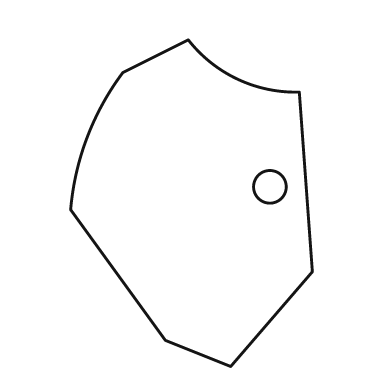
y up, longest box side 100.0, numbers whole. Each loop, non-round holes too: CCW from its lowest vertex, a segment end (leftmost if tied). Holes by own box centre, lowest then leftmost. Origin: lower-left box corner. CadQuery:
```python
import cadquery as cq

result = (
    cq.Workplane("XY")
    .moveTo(49.0, 0.0)
    .lineTo(74.0, 29.0)
    .lineTo(70.0, 84.0)
    .threePointArc((51.0, 88.0), (36.0, 100.0))
    .lineTo(16.0, 90.0)
    .threePointArc((5.0, 70.0), (0.0, 48.0))
    .lineTo(29.0, 8.0)
    .close()
    .moveTo(61.0, 55.0)
    .circle(5.0)
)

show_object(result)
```